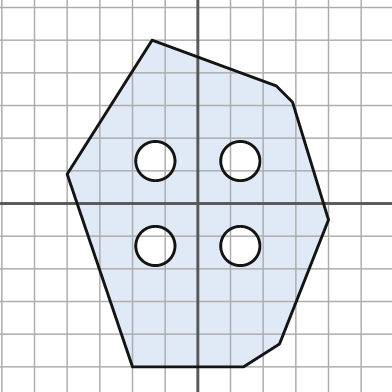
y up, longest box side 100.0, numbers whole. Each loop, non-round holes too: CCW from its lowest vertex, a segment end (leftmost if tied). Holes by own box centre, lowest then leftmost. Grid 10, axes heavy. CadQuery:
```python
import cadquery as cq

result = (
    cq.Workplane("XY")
    .moveTo(-20.0, -50.0)
    .lineTo(14.0, -50.0)
    .lineTo(25.0, -43.0)
    .lineTo(40.0, -5.0)
    .lineTo(29.0, 31.0)
    .lineTo(24.0, 36.0)
    .lineTo(-14.0, 50.0)
    .lineTo(-40.0, 9.0)
    .close()
    .moveTo(-13.0, -13.0)
    .circle(6.0)
    .moveTo(13.0, -13.0)
    .circle(6.0)
    .moveTo(-13.0, 13.0)
    .circle(6.0)
    .moveTo(13.0, 13.0)
    .circle(6.0)
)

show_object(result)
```